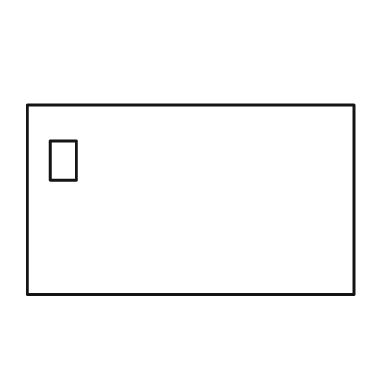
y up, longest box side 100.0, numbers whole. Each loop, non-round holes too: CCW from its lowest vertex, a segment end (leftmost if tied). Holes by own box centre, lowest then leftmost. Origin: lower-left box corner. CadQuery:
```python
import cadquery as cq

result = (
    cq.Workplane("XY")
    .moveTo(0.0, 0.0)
    .lineTo(100.0, 0.0)
    .lineTo(100.0, 58.0)
    .lineTo(0.0, 58.0)
    .close()
    .moveTo(7.0, 35.0)
    .lineTo(15.0, 35.0)
    .lineTo(15.0, 47.0)
    .lineTo(7.0, 47.0)
    .close()
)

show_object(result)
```